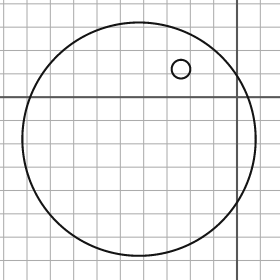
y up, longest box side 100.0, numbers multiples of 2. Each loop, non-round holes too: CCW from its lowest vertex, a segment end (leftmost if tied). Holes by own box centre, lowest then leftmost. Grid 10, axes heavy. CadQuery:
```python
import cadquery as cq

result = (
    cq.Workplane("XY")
    .moveTo(-42.0, -18.0)
    .circle(50.0)
    .moveTo(-24.0, 12.0)
    .circle(4.0)
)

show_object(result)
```